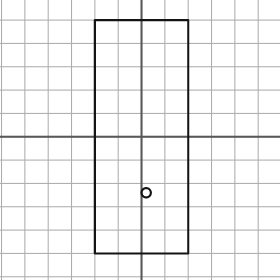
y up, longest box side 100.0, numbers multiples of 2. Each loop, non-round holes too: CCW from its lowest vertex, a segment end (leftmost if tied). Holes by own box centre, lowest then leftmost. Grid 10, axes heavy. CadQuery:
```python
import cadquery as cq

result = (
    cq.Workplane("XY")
    .moveTo(-20.0, -50.0)
    .lineTo(20.0, -50.0)
    .lineTo(20.0, 50.0)
    .lineTo(-20.0, 50.0)
    .close()
    .moveTo(2.0, -24.0)
    .circle(2.0)
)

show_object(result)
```